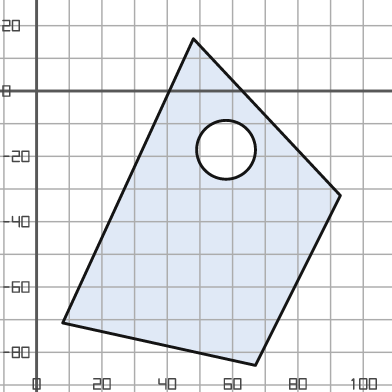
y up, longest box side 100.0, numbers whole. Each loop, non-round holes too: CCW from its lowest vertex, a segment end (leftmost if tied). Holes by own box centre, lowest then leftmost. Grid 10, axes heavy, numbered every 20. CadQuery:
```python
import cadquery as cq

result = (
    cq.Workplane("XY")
    .moveTo(67.0, -84.0)
    .lineTo(93.0, -32.0)
    .lineTo(48.0, 16.0)
    .lineTo(8.0, -71.0)
    .close()
    .moveTo(58.0, -18.0)
    .circle(9.0)
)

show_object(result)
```